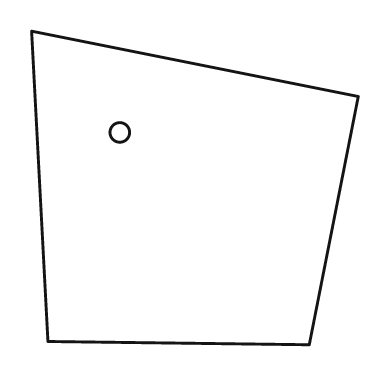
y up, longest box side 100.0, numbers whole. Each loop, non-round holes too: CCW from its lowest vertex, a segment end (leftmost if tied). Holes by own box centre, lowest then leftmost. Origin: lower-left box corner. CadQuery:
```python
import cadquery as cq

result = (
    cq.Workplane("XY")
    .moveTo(85.0, 0.0)
    .lineTo(100.0, 76.0)
    .lineTo(0.0, 96.0)
    .lineTo(5.0, 1.0)
    .close()
    .moveTo(27.0, 65.0)
    .circle(3.0)
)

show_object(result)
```